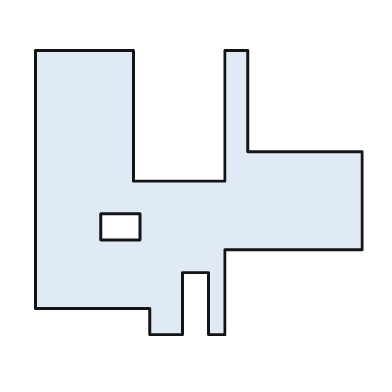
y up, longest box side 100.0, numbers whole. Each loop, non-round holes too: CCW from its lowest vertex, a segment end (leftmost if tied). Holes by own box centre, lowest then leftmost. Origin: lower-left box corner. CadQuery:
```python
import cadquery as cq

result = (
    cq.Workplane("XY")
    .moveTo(35.0, 0.0)
    .lineTo(45.0, 0.0)
    .lineTo(45.0, 19.0)
    .lineTo(53.0, 19.0)
    .lineTo(53.0, 0.0)
    .lineTo(58.0, 0.0)
    .lineTo(58.0, 26.0)
    .lineTo(100.0, 26.0)
    .lineTo(100.0, 56.0)
    .lineTo(65.0, 56.0)
    .lineTo(65.0, 87.0)
    .lineTo(58.0, 87.0)
    .lineTo(58.0, 47.0)
    .lineTo(30.0, 47.0)
    .lineTo(30.0, 87.0)
    .lineTo(0.0, 87.0)
    .lineTo(0.0, 8.0)
    .lineTo(35.0, 8.0)
    .close()
    .moveTo(20.0, 29.0)
    .lineTo(32.0, 29.0)
    .lineTo(32.0, 37.0)
    .lineTo(20.0, 37.0)
    .close()
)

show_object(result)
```